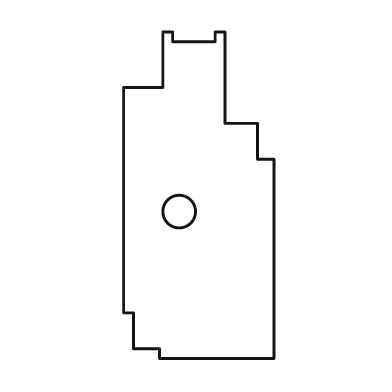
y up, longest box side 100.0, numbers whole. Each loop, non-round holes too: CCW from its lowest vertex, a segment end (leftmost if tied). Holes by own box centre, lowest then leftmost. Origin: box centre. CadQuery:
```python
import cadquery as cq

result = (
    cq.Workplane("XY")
    .moveTo(-12.0, -50.0)
    .lineTo(23.0, -50.0)
    .lineTo(23.0, 11.0)
    .lineTo(18.0, 11.0)
    .lineTo(18.0, 22.0)
    .lineTo(8.0, 22.0)
    .lineTo(8.0, 50.0)
    .lineTo(5.0, 50.0)
    .lineTo(5.0, 47.0)
    .lineTo(-8.0, 47.0)
    .lineTo(-8.0, 50.0)
    .lineTo(-11.0, 50.0)
    .lineTo(-11.0, 33.0)
    .lineTo(-23.0, 33.0)
    .lineTo(-23.0, -36.0)
    .lineTo(-20.0, -36.0)
    .lineTo(-20.0, -47.0)
    .lineTo(-12.0, -47.0)
    .close()
    .moveTo(-6.0, -5.0)
    .circle(5.0)
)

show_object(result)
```